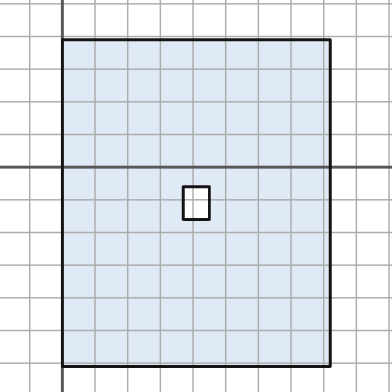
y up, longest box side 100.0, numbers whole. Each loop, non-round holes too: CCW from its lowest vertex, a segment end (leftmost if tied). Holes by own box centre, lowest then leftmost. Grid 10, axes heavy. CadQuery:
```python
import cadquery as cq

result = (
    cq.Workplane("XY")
    .moveTo(0.0, -61.0)
    .lineTo(82.0, -61.0)
    .lineTo(82.0, 39.0)
    .lineTo(0.0, 39.0)
    .close()
    .moveTo(37.0, -16.0)
    .lineTo(45.0, -16.0)
    .lineTo(45.0, -6.0)
    .lineTo(37.0, -6.0)
    .close()
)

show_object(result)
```